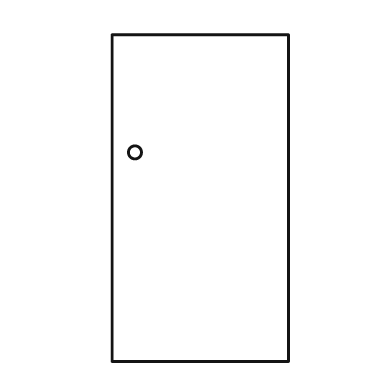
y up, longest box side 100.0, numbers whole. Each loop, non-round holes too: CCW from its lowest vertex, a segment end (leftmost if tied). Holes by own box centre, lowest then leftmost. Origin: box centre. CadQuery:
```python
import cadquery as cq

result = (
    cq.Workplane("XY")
    .moveTo(-27.0, -50.0)
    .lineTo(27.0, -50.0)
    .lineTo(27.0, 50.0)
    .lineTo(-27.0, 50.0)
    .close()
    .moveTo(-20.0, 14.0)
    .circle(2.0)
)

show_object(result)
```